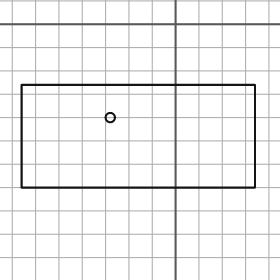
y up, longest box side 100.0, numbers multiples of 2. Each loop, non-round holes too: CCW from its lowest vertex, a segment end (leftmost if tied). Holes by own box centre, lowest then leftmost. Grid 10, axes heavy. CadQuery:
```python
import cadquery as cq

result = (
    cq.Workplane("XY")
    .moveTo(-66.0, -70.0)
    .lineTo(34.0, -70.0)
    .lineTo(34.0, -26.0)
    .lineTo(-66.0, -26.0)
    .close()
    .moveTo(-28.0, -40.0)
    .circle(2.0)
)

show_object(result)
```